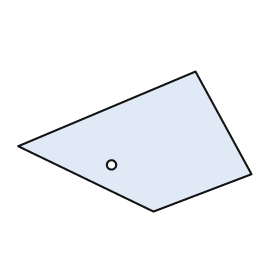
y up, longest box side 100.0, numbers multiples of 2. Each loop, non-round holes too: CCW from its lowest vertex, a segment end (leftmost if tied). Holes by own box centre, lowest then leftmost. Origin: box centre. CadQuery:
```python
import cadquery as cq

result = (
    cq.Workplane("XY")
    .moveTo(8.0, -30.0)
    .lineTo(50.0, -14.0)
    .lineTo(26.0, 30.0)
    .lineTo(-50.0, -2.0)
    .close()
    .moveTo(-10.0, -10.0)
    .circle(2.0)
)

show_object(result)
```